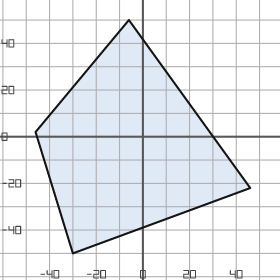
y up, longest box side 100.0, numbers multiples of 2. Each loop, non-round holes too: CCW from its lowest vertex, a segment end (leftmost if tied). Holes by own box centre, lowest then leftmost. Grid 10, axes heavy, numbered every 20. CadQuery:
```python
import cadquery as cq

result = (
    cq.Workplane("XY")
    .moveTo(-30.0, -50.0)
    .lineTo(46.0, -22.0)
    .lineTo(-6.0, 50.0)
    .lineTo(-46.0, 2.0)
    .close()
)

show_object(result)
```